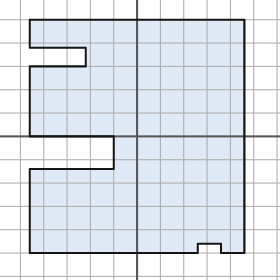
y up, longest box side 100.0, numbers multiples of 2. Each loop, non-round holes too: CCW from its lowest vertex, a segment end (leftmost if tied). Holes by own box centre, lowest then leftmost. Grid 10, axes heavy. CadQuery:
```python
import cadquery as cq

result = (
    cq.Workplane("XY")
    .moveTo(-46.0, -50.0)
    .lineTo(26.0, -50.0)
    .lineTo(26.0, -46.0)
    .lineTo(36.0, -46.0)
    .lineTo(36.0, -50.0)
    .lineTo(46.0, -50.0)
    .lineTo(46.0, 50.0)
    .lineTo(-46.0, 50.0)
    .lineTo(-46.0, 38.0)
    .lineTo(-22.0, 38.0)
    .lineTo(-22.0, 30.0)
    .lineTo(-46.0, 30.0)
    .lineTo(-46.0, 0.0)
    .lineTo(-10.0, 0.0)
    .lineTo(-10.0, -14.0)
    .lineTo(-46.0, -14.0)
    .close()
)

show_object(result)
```